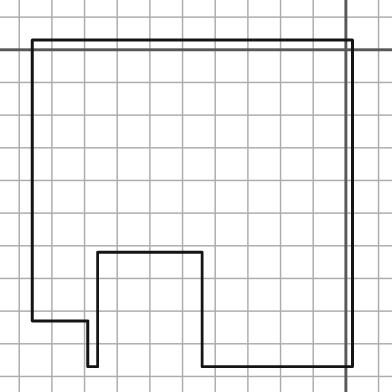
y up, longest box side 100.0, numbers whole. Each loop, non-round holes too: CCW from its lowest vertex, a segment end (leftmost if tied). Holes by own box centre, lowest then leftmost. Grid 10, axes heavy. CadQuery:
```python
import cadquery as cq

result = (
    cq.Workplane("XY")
    .moveTo(-79.0, -97.0)
    .lineTo(-76.0, -97.0)
    .lineTo(-76.0, -62.0)
    .lineTo(-44.0, -62.0)
    .lineTo(-44.0, -97.0)
    .lineTo(2.0, -97.0)
    .lineTo(2.0, 3.0)
    .lineTo(-96.0, 3.0)
    .lineTo(-96.0, -83.0)
    .lineTo(-79.0, -83.0)
    .close()
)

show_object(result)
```